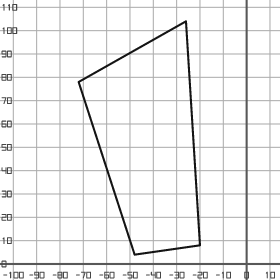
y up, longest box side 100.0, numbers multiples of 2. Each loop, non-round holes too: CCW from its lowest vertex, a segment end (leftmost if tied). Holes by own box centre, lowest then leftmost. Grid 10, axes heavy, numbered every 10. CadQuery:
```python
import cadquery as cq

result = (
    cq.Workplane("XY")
    .moveTo(-48.0, 4.0)
    .lineTo(-20.0, 8.0)
    .lineTo(-26.0, 104.0)
    .lineTo(-72.0, 78.0)
    .close()
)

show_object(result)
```